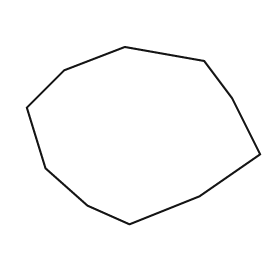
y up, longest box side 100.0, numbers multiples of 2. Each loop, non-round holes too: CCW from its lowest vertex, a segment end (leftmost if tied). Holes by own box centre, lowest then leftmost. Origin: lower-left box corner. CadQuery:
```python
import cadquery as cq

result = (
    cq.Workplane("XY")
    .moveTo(44.0, 0.0)
    .lineTo(74.0, 12.0)
    .lineTo(100.0, 30.0)
    .lineTo(88.0, 54.0)
    .lineTo(76.0, 70.0)
    .lineTo(42.0, 76.0)
    .lineTo(16.0, 66.0)
    .lineTo(0.0, 50.0)
    .lineTo(8.0, 24.0)
    .lineTo(26.0, 8.0)
    .close()
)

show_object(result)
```